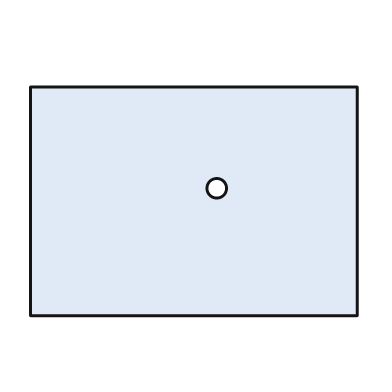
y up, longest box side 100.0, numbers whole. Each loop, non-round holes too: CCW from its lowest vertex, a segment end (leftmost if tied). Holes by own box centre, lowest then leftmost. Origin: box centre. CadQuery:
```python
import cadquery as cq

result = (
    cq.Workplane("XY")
    .moveTo(-50.0, -35.0)
    .lineTo(50.0, -35.0)
    .lineTo(50.0, 35.0)
    .lineTo(-50.0, 35.0)
    .close()
    .moveTo(7.0, 4.0)
    .circle(3.0)
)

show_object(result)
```